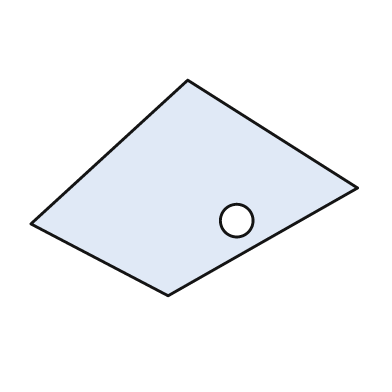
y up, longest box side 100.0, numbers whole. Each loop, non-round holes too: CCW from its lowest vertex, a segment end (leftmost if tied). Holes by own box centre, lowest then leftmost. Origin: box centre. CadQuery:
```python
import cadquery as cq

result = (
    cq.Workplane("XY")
    .moveTo(-8.0, -33.0)
    .lineTo(50.0, 0.0)
    .lineTo(-2.0, 33.0)
    .lineTo(-50.0, -11.0)
    .close()
    .moveTo(13.0, -10.0)
    .circle(5.0)
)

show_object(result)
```